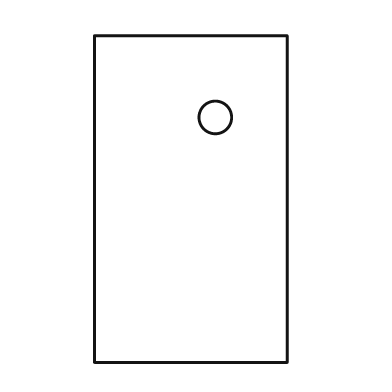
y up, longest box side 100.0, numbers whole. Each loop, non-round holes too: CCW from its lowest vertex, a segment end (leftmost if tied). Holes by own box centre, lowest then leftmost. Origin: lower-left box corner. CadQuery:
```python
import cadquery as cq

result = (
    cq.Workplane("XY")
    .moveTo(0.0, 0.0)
    .lineTo(59.0, 0.0)
    .lineTo(59.0, 100.0)
    .lineTo(0.0, 100.0)
    .close()
    .moveTo(37.0, 75.0)
    .circle(5.0)
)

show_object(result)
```